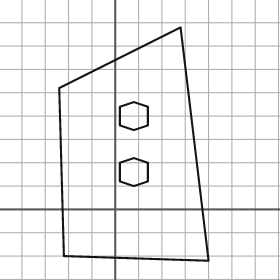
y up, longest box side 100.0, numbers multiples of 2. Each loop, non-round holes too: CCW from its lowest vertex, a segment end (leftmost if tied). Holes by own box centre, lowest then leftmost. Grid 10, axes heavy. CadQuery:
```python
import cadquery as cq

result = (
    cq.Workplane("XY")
    .moveTo(40.0, -22.0)
    .lineTo(28.0, 78.0)
    .lineTo(-24.0, 52.0)
    .lineTo(-22.0, -20.0)
    .close()
    .moveTo(8.0, 10.0)
    .lineTo(14.0, 12.0)
    .lineTo(14.0, 20.0)
    .lineTo(8.0, 22.0)
    .lineTo(2.0, 20.0)
    .lineTo(2.0, 12.0)
    .close()
    .moveTo(8.0, 34.0)
    .lineTo(14.0, 36.0)
    .lineTo(14.0, 44.0)
    .lineTo(8.0, 46.0)
    .lineTo(2.0, 44.0)
    .lineTo(2.0, 36.0)
    .close()
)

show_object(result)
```